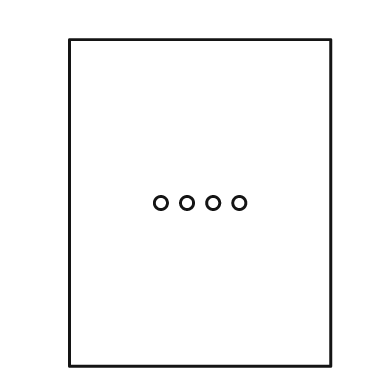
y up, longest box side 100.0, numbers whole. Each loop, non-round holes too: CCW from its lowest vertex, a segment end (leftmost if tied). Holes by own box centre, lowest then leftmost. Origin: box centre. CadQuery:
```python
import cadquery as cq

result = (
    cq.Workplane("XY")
    .moveTo(-40.0, -50.0)
    .lineTo(40.0, -50.0)
    .lineTo(40.0, 50.0)
    .lineTo(-40.0, 50.0)
    .close()
    .moveTo(-12.0, 0.0)
    .circle(2.0)
    .moveTo(-4.0, 0.0)
    .circle(2.0)
    .moveTo(4.0, 0.0)
    .circle(2.0)
    .moveTo(12.0, 0.0)
    .circle(2.0)
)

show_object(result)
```